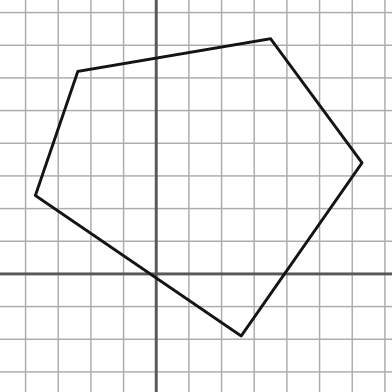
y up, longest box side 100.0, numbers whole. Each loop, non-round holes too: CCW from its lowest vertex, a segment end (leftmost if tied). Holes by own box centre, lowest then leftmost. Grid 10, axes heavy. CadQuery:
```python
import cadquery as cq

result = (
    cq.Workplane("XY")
    .moveTo(26.0, -19.0)
    .lineTo(63.0, 34.0)
    .lineTo(35.0, 72.0)
    .lineTo(-24.0, 62.0)
    .lineTo(-37.0, 24.0)
    .close()
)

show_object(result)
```